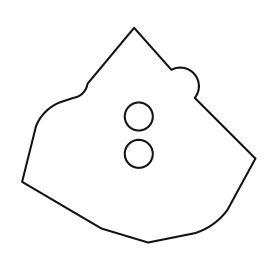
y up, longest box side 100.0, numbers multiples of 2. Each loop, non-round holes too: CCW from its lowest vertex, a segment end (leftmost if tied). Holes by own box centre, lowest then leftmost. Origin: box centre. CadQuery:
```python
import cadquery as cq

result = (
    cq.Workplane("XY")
    .moveTo(4.0, -46.0)
    .lineTo(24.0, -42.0)
    .threePointArc((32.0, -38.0), (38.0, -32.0))
    .lineTo(50.0, -10.0)
    .lineTo(24.0, 16.0)
    .threePointArc((24.0, 26.0), (14.0, 28.0))
    .lineTo(-2.0, 46.0)
    .lineTo(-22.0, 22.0)
    .threePointArc((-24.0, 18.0), (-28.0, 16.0))
    .lineTo(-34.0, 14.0)
    .threePointArc((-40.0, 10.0), (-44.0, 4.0))
    .lineTo(-50.0, -20.0)
    .lineTo(-16.0, -40.0)
    .close()
    .moveTo(0.0, -8.0)
    .circle(6.0)
    .moveTo(0.0, 8.0)
    .circle(6.0)
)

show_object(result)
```